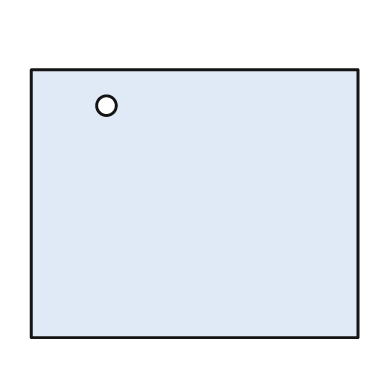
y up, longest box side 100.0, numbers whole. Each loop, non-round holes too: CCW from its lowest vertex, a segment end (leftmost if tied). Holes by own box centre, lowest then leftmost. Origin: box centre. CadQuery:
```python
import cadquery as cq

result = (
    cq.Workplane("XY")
    .moveTo(-50.0, -41.0)
    .lineTo(50.0, -41.0)
    .lineTo(50.0, 41.0)
    .lineTo(-50.0, 41.0)
    .close()
    .moveTo(-27.0, 30.0)
    .circle(3.0)
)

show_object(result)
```